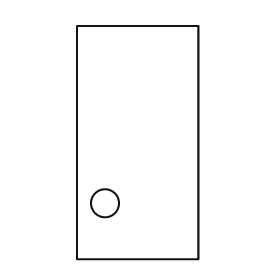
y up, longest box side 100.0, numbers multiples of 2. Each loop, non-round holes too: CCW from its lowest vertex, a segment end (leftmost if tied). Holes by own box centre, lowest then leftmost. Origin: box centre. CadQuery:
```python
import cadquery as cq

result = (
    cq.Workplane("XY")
    .moveTo(-26.0, -50.0)
    .lineTo(26.0, -50.0)
    .lineTo(26.0, 50.0)
    .lineTo(-26.0, 50.0)
    .close()
    .moveTo(-14.0, -26.0)
    .circle(6.0)
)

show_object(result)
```